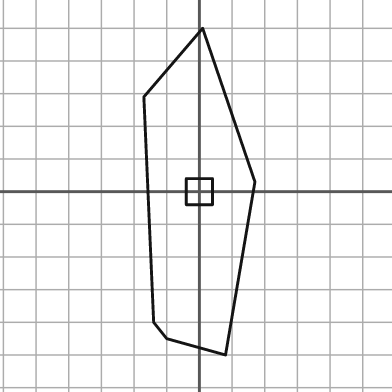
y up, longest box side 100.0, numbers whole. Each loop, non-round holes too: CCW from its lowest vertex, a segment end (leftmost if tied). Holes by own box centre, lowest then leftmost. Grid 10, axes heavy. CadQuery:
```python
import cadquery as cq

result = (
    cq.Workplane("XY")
    .moveTo(8.0, -50.0)
    .lineTo(17.0, 3.0)
    .lineTo(1.0, 50.0)
    .lineTo(-17.0, 29.0)
    .lineTo(-14.0, -40.0)
    .lineTo(-10.0, -45.0)
    .close()
    .moveTo(-4.0, -4.0)
    .lineTo(4.0, -4.0)
    .lineTo(4.0, 4.0)
    .lineTo(-4.0, 4.0)
    .close()
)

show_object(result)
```